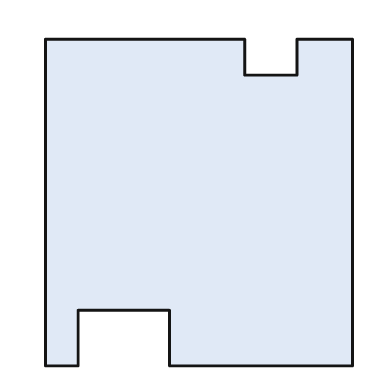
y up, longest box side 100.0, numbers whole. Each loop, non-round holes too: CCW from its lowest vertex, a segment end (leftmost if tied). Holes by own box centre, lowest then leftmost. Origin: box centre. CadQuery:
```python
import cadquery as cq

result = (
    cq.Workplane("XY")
    .moveTo(-47.0, -50.0)
    .lineTo(-37.0, -50.0)
    .lineTo(-37.0, -33.0)
    .lineTo(-9.0, -33.0)
    .lineTo(-9.0, -50.0)
    .lineTo(47.0, -50.0)
    .lineTo(47.0, 50.0)
    .lineTo(30.0, 50.0)
    .lineTo(30.0, 39.0)
    .lineTo(14.0, 39.0)
    .lineTo(14.0, 50.0)
    .lineTo(-47.0, 50.0)
    .close()
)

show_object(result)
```